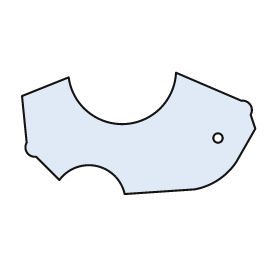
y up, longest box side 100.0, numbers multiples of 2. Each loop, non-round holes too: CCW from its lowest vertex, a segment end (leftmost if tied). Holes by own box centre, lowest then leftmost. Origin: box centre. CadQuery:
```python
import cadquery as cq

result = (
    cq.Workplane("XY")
    .moveTo(-6.0, -26.0)
    .lineTo(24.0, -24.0)
    .threePointArc((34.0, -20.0), (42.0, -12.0))
    .lineTo(50.0, 2.0)
    .lineTo(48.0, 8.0)
    .threePointArc((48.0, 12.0), (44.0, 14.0))
    .lineTo(16.0, 26.0)
    .threePointArc((-6.0, 4.0), (-30.0, 24.0))
    .lineTo(-50.0, 16.0)
    .lineTo(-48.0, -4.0)
    .threePointArc((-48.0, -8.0), (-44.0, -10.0))
    .lineTo(-34.0, -20.0)
    .threePointArc((-18.0, -14.0), (-6.0, -26.0))
    .close()
    .moveTo(34.0, -2.0)
    .circle(2.0)
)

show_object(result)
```